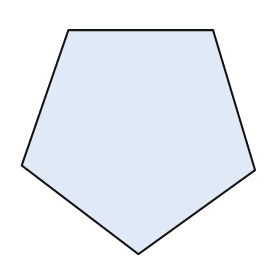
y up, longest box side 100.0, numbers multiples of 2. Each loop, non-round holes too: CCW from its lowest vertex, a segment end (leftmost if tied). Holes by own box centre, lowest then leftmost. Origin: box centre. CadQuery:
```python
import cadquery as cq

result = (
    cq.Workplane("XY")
    .moveTo(0.0, -48.0)
    .lineTo(50.0, -12.0)
    .lineTo(32.0, 48.0)
    .lineTo(-30.0, 48.0)
    .lineTo(-50.0, -10.0)
    .close()
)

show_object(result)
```